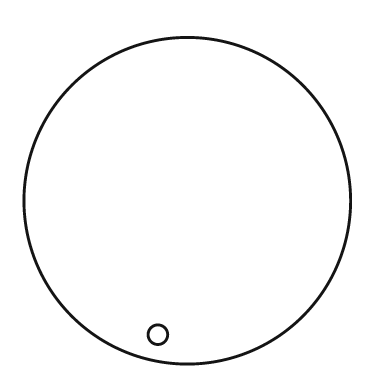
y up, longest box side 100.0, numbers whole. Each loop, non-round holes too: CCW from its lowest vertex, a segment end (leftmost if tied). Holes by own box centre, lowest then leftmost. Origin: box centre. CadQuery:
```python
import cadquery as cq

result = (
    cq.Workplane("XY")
    .moveTo(0.0, 0.0)
    .circle(50.0)
    .moveTo(-9.0, -41.0)
    .circle(3.0)
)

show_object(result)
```